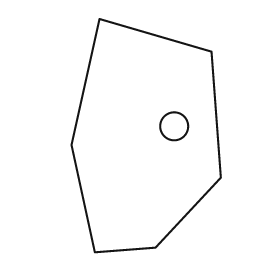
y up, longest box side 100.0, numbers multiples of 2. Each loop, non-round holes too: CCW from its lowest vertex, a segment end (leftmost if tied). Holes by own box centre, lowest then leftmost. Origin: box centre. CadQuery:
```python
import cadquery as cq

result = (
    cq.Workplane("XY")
    .moveTo(-22.0, -50.0)
    .lineTo(4.0, -48.0)
    .lineTo(32.0, -18.0)
    .lineTo(28.0, 36.0)
    .lineTo(-20.0, 50.0)
    .lineTo(-32.0, -4.0)
    .close()
    .moveTo(12.0, 4.0)
    .circle(6.0)
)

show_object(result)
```